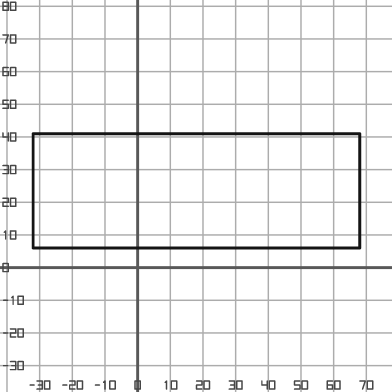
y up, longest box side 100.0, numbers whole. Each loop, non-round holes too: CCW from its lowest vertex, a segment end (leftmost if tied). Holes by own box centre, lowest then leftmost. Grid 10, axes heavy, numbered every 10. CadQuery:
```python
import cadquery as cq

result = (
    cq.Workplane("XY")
    .moveTo(-32.0, 6.0)
    .lineTo(68.0, 6.0)
    .lineTo(68.0, 41.0)
    .lineTo(-32.0, 41.0)
    .close()
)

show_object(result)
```